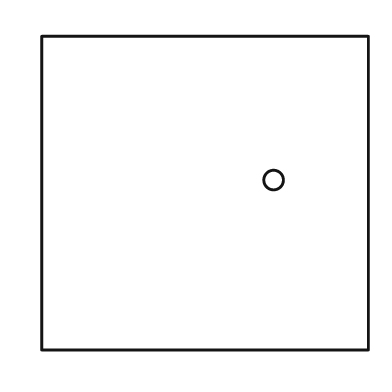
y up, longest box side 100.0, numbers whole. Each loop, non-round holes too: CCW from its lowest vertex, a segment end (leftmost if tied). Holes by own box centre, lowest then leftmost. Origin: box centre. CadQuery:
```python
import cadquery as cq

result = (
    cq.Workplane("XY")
    .moveTo(-50.0, -48.0)
    .lineTo(50.0, -48.0)
    .lineTo(50.0, 48.0)
    .lineTo(-50.0, 48.0)
    .close()
    .moveTo(21.0, 4.0)
    .circle(3.0)
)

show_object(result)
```